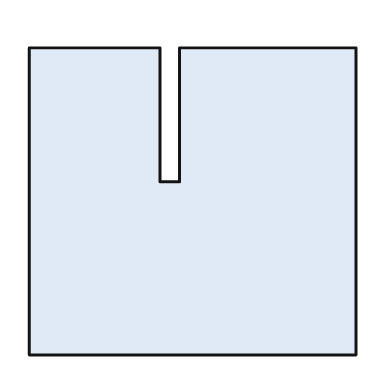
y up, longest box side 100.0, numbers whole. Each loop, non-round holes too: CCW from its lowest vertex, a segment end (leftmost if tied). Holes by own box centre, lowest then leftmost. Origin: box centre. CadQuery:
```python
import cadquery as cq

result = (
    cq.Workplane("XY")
    .moveTo(-50.0, -47.0)
    .lineTo(50.0, -47.0)
    .lineTo(50.0, 47.0)
    .lineTo(-4.0, 47.0)
    .lineTo(-4.0, 6.0)
    .lineTo(-10.0, 6.0)
    .lineTo(-10.0, 47.0)
    .lineTo(-50.0, 47.0)
    .close()
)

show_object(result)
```